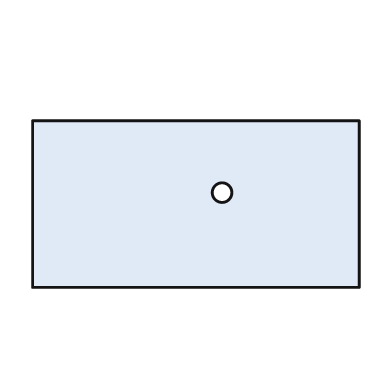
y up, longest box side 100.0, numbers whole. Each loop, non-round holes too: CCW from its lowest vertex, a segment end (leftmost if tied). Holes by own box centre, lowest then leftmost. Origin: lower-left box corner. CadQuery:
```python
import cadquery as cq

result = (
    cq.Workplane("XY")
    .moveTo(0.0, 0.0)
    .lineTo(100.0, 0.0)
    .lineTo(100.0, 51.0)
    .lineTo(0.0, 51.0)
    .close()
    .moveTo(58.0, 29.0)
    .circle(3.0)
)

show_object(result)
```